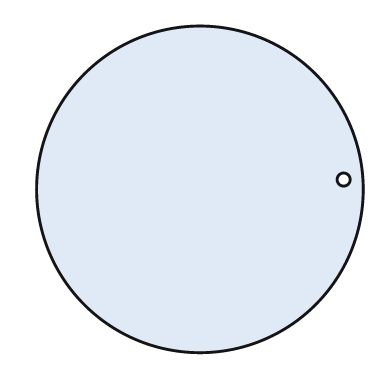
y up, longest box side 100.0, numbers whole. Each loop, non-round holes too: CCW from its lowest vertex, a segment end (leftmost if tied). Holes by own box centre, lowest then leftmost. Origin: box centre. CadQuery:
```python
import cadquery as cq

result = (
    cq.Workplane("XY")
    .moveTo(0.0, 0.0)
    .circle(50.0)
    .moveTo(44.0, 3.0)
    .circle(2.0)
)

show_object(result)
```